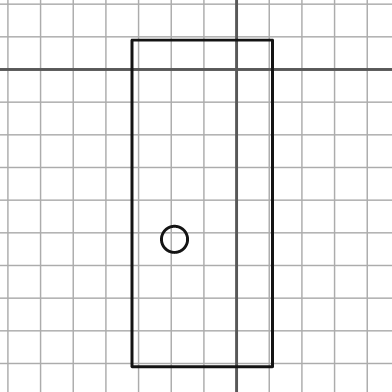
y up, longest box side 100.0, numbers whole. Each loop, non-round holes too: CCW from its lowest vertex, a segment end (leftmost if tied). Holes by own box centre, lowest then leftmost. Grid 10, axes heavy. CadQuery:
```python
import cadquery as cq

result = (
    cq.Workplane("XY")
    .moveTo(-32.0, -91.0)
    .lineTo(11.0, -91.0)
    .lineTo(11.0, 9.0)
    .lineTo(-32.0, 9.0)
    .close()
    .moveTo(-19.0, -52.0)
    .circle(4.0)
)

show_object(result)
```